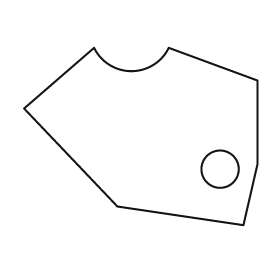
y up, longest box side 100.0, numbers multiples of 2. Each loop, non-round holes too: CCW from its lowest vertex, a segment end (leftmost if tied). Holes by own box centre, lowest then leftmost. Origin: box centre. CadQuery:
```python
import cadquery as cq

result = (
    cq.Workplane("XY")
    .moveTo(44.0, -38.0)
    .lineTo(50.0, -12.0)
    .lineTo(50.0, 24.0)
    .lineTo(12.0, 38.0)
    .threePointArc((-4.0, 28.0), (-20.0, 38.0))
    .lineTo(-50.0, 12.0)
    .lineTo(-10.0, -30.0)
    .close()
    .moveTo(34.0, -14.0)
    .circle(8.0)
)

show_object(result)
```